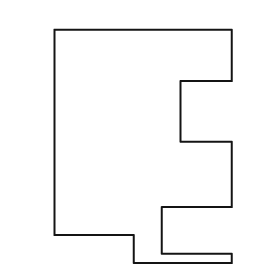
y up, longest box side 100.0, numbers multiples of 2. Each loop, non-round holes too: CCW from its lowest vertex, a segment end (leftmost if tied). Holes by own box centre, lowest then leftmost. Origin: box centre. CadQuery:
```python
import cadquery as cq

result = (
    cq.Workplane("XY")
    .moveTo(-4.0, -50.0)
    .lineTo(38.0, -50.0)
    .lineTo(38.0, -46.0)
    .lineTo(8.0, -46.0)
    .lineTo(8.0, -26.0)
    .lineTo(38.0, -26.0)
    .lineTo(38.0, 2.0)
    .lineTo(16.0, 2.0)
    .lineTo(16.0, 28.0)
    .lineTo(38.0, 28.0)
    .lineTo(38.0, 50.0)
    .lineTo(-38.0, 50.0)
    .lineTo(-38.0, -38.0)
    .lineTo(-4.0, -38.0)
    .close()
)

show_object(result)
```